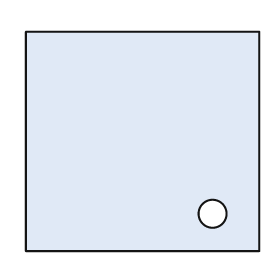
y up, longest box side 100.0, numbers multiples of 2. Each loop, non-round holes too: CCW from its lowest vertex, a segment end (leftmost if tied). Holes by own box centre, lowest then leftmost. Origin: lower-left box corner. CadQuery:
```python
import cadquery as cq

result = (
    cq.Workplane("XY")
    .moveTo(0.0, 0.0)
    .lineTo(100.0, 0.0)
    .lineTo(100.0, 94.0)
    .lineTo(0.0, 94.0)
    .close()
    .moveTo(80.0, 16.0)
    .circle(6.0)
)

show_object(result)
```